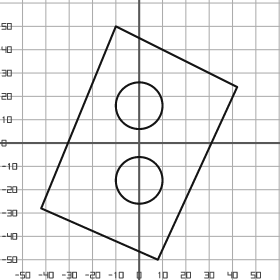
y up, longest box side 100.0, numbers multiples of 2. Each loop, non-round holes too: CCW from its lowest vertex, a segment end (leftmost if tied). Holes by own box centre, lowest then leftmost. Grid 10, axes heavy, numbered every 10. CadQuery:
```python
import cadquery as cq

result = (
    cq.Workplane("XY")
    .moveTo(8.0, -50.0)
    .lineTo(42.0, 24.0)
    .lineTo(-10.0, 50.0)
    .lineTo(-42.0, -28.0)
    .close()
    .moveTo(0.0, -16.0)
    .circle(10.0)
    .moveTo(0.0, 16.0)
    .circle(10.0)
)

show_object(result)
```